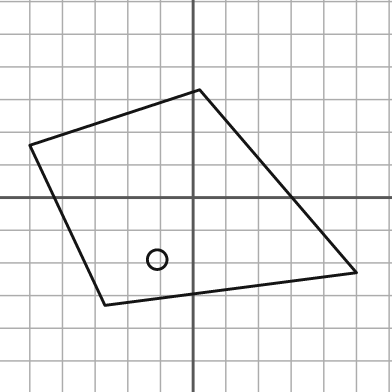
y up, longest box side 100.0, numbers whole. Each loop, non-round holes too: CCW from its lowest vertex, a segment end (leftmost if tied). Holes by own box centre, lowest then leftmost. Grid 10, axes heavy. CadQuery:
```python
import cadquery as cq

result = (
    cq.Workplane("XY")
    .moveTo(-27.0, -33.0)
    .lineTo(50.0, -23.0)
    .lineTo(2.0, 33.0)
    .lineTo(-50.0, 16.0)
    .close()
    .moveTo(-11.0, -19.0)
    .circle(3.0)
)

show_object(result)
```